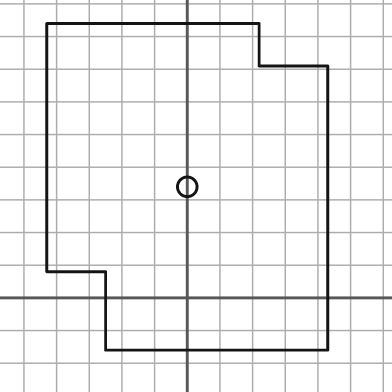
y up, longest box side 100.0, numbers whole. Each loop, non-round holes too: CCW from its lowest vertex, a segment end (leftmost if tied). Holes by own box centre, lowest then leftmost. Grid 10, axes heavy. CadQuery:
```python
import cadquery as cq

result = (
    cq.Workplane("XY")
    .moveTo(-25.0, -16.0)
    .lineTo(43.0, -16.0)
    .lineTo(43.0, 71.0)
    .lineTo(22.0, 71.0)
    .lineTo(22.0, 84.0)
    .lineTo(-43.0, 84.0)
    .lineTo(-43.0, 8.0)
    .lineTo(-25.0, 8.0)
    .close()
    .moveTo(0.0, 34.0)
    .circle(3.0)
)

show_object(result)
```